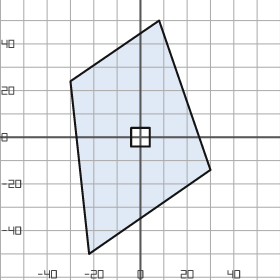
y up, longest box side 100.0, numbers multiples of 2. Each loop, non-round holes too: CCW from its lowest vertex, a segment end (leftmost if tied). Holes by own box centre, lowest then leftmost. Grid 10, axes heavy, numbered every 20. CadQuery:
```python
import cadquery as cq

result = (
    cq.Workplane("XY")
    .moveTo(-22.0, -50.0)
    .lineTo(30.0, -14.0)
    .lineTo(8.0, 50.0)
    .lineTo(-30.0, 24.0)
    .close()
    .moveTo(-4.0, -4.0)
    .lineTo(4.0, -4.0)
    .lineTo(4.0, 4.0)
    .lineTo(-4.0, 4.0)
    .close()
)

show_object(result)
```